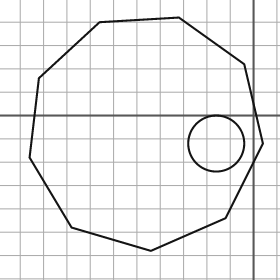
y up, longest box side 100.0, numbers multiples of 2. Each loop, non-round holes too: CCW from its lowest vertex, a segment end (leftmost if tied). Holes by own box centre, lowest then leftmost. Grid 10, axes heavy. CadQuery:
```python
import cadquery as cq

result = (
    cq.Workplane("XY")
    .moveTo(-44.0, -58.0)
    .lineTo(-12.0, -44.0)
    .lineTo(4.0, -12.0)
    .lineTo(-4.0, 22.0)
    .lineTo(-32.0, 42.0)
    .lineTo(-66.0, 40.0)
    .lineTo(-92.0, 16.0)
    .lineTo(-96.0, -18.0)
    .lineTo(-78.0, -48.0)
    .close()
    .moveTo(-16.0, -12.0)
    .circle(12.0)
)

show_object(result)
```